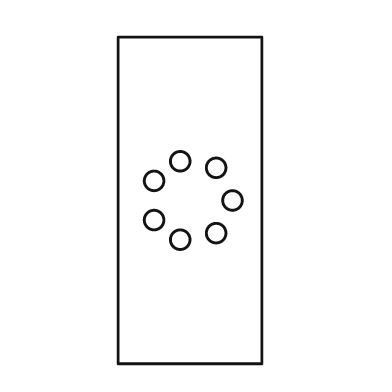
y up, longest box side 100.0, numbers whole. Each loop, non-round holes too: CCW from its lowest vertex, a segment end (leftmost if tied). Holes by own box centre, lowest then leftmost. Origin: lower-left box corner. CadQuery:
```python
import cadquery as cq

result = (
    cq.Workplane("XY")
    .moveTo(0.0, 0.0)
    .lineTo(44.0, 0.0)
    .lineTo(44.0, 100.0)
    .lineTo(0.0, 100.0)
    .close()
    .moveTo(19.0, 38.0)
    .circle(3.0)
    .moveTo(30.0, 40.0)
    .circle(3.0)
    .moveTo(11.0, 44.0)
    .circle(3.0)
    .moveTo(35.0, 50.0)
    .circle(3.0)
    .moveTo(11.0, 56.0)
    .circle(3.0)
    .moveTo(30.0, 60.0)
    .circle(3.0)
    .moveTo(19.0, 62.0)
    .circle(3.0)
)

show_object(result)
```